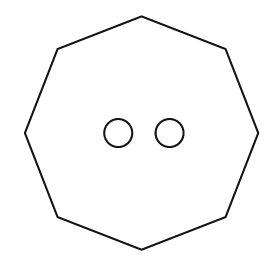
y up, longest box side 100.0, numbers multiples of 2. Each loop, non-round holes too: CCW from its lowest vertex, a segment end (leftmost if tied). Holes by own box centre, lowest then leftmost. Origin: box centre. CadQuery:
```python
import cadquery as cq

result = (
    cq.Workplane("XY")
    .moveTo(0.0, -50.0)
    .lineTo(36.0, -36.0)
    .lineTo(50.0, 0.0)
    .lineTo(36.0, 36.0)
    .lineTo(0.0, 50.0)
    .lineTo(-36.0, 36.0)
    .lineTo(-50.0, 0.0)
    .lineTo(-36.0, -36.0)
    .close()
    .moveTo(-10.0, 0.0)
    .circle(6.0)
    .moveTo(12.0, 0.0)
    .circle(6.0)
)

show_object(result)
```